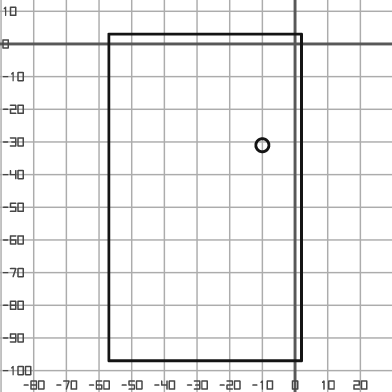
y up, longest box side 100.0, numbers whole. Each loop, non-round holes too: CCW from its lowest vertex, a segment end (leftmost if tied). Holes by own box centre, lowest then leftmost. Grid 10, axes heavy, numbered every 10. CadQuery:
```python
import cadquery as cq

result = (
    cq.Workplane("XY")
    .moveTo(-57.0, -97.0)
    .lineTo(2.0, -97.0)
    .lineTo(2.0, 3.0)
    .lineTo(-57.0, 3.0)
    .close()
    .moveTo(-10.0, -31.0)
    .circle(2.0)
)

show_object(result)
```